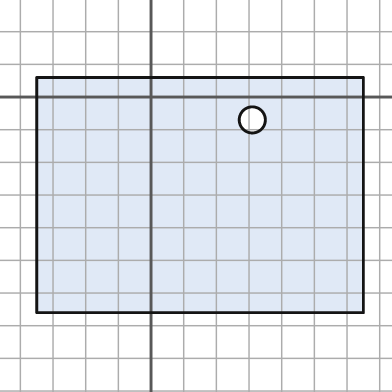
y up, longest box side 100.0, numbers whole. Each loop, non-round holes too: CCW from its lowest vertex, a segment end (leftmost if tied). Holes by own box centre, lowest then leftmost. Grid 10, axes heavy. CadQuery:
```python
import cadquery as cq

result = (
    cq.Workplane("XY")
    .moveTo(-35.0, -66.0)
    .lineTo(65.0, -66.0)
    .lineTo(65.0, 6.0)
    .lineTo(-35.0, 6.0)
    .close()
    .moveTo(31.0, -7.0)
    .circle(4.0)
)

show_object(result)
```